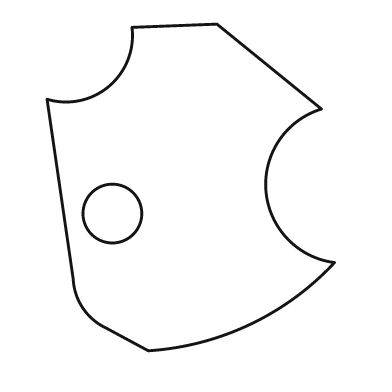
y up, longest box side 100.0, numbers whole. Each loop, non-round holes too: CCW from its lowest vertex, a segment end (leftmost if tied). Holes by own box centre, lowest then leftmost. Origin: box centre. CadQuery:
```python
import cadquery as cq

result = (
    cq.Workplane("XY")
    .moveTo(-13.0, -50.0)
    .threePointArc((18.0, -42.0), (44.0, -23.0))
    .threePointArc((23.0, -1.0), (40.0, 24.0))
    .lineTo(8.0, 50.0)
    .lineTo(-18.0, 49.0)
    .threePointArc((-25.0, 31.0), (-44.0, 27.0))
    .lineTo(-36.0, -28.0)
    .threePointArc((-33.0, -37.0), (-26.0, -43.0))
    .close()
    .moveTo(-24.0, -8.0)
    .circle(9.0)
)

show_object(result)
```